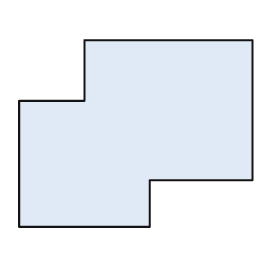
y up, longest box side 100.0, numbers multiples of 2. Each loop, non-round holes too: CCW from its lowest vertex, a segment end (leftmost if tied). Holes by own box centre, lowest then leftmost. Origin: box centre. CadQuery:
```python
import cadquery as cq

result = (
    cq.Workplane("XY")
    .moveTo(-50.0, -40.0)
    .lineTo(6.0, -40.0)
    .lineTo(6.0, -20.0)
    .lineTo(50.0, -20.0)
    .lineTo(50.0, 40.0)
    .lineTo(-22.0, 40.0)
    .lineTo(-22.0, 14.0)
    .lineTo(-50.0, 14.0)
    .close()
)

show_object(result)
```